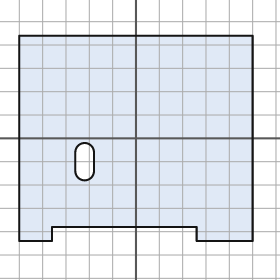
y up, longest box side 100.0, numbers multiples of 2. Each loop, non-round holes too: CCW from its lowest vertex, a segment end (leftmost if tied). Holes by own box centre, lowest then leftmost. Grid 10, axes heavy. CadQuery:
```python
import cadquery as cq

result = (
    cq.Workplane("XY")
    .moveTo(-50.0, -44.0)
    .lineTo(-36.0, -44.0)
    .lineTo(-36.0, -38.0)
    .lineTo(26.0, -38.0)
    .lineTo(26.0, -44.0)
    .lineTo(50.0, -44.0)
    .lineTo(50.0, 44.0)
    .lineTo(-50.0, 44.0)
    .close()
    .moveTo(-26.0, -14.0)
    .threePointArc((-22.0, -18.0), (-18.0, -14.0))
    .lineTo(-18.0, -6.0)
    .threePointArc((-22.0, -2.0), (-26.0, -6.0))
    .close()
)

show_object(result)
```